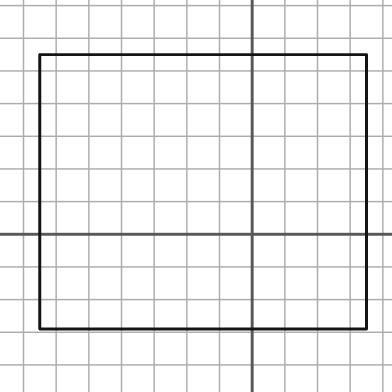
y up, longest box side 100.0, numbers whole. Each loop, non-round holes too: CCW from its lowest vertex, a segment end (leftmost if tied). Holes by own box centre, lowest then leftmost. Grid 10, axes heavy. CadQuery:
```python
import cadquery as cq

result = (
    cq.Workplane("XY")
    .moveTo(-65.0, -29.0)
    .lineTo(35.0, -29.0)
    .lineTo(35.0, 55.0)
    .lineTo(-65.0, 55.0)
    .close()
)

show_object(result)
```